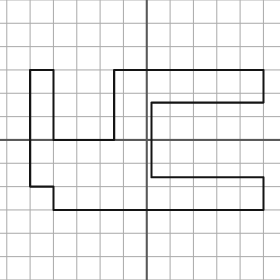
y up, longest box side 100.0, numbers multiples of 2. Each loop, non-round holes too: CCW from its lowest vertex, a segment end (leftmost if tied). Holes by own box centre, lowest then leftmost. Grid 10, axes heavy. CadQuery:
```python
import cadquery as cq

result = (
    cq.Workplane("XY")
    .moveTo(-40.0, -30.0)
    .lineTo(50.0, -30.0)
    .lineTo(50.0, -16.0)
    .lineTo(2.0, -16.0)
    .lineTo(2.0, 16.0)
    .lineTo(50.0, 16.0)
    .lineTo(50.0, 30.0)
    .lineTo(-14.0, 30.0)
    .lineTo(-14.0, 0.0)
    .lineTo(-40.0, 0.0)
    .lineTo(-40.0, 30.0)
    .lineTo(-50.0, 30.0)
    .lineTo(-50.0, -20.0)
    .lineTo(-40.0, -20.0)
    .close()
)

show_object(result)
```